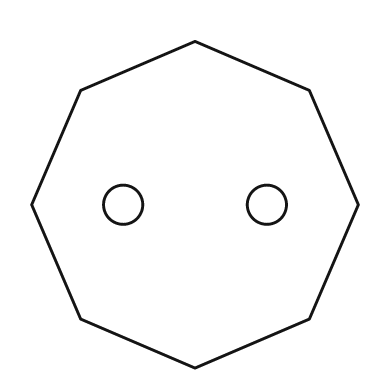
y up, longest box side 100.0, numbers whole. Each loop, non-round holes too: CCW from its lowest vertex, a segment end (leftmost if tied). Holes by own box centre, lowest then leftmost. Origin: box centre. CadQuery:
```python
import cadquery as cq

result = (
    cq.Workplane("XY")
    .moveTo(0.0, -50.0)
    .lineTo(35.0, -35.0)
    .lineTo(50.0, 0.0)
    .lineTo(35.0, 35.0)
    .lineTo(0.0, 50.0)
    .lineTo(-35.0, 35.0)
    .lineTo(-50.0, 0.0)
    .lineTo(-35.0, -35.0)
    .close()
    .moveTo(-22.0, 0.0)
    .circle(6.0)
    .moveTo(22.0, 0.0)
    .circle(6.0)
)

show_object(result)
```